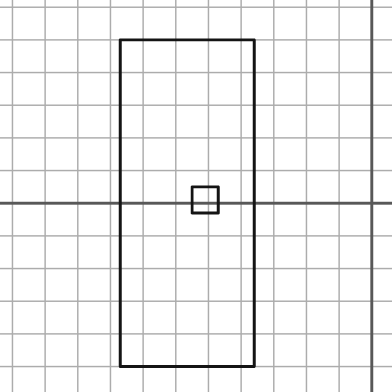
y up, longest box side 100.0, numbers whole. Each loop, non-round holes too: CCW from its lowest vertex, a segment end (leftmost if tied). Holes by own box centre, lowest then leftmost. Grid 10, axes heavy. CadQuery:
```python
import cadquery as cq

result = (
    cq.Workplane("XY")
    .moveTo(-77.0, -50.0)
    .lineTo(-36.0, -50.0)
    .lineTo(-36.0, 50.0)
    .lineTo(-77.0, 50.0)
    .close()
    .moveTo(-55.0, -3.0)
    .lineTo(-47.0, -3.0)
    .lineTo(-47.0, 5.0)
    .lineTo(-55.0, 5.0)
    .close()
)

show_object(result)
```